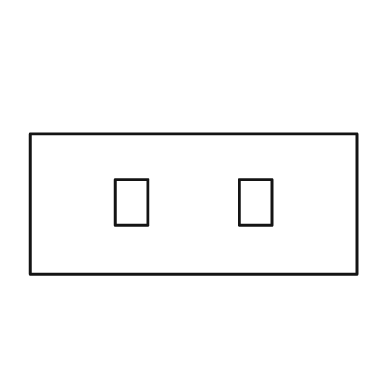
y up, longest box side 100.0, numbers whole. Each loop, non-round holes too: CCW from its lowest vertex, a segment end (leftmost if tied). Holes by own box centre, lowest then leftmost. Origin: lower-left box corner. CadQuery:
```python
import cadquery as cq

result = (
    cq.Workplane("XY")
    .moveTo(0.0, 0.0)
    .lineTo(100.0, 0.0)
    .lineTo(100.0, 43.0)
    .lineTo(0.0, 43.0)
    .close()
    .moveTo(26.0, 15.0)
    .lineTo(36.0, 15.0)
    .lineTo(36.0, 29.0)
    .lineTo(26.0, 29.0)
    .close()
    .moveTo(64.0, 15.0)
    .lineTo(74.0, 15.0)
    .lineTo(74.0, 29.0)
    .lineTo(64.0, 29.0)
    .close()
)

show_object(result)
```